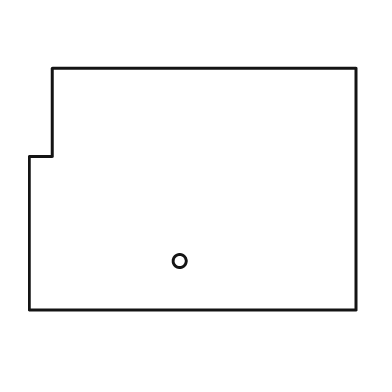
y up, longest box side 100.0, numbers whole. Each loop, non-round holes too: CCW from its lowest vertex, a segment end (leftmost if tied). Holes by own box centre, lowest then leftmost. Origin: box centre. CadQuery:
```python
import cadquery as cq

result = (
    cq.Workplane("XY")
    .moveTo(-50.0, -37.0)
    .lineTo(50.0, -37.0)
    .lineTo(50.0, 37.0)
    .lineTo(-43.0, 37.0)
    .lineTo(-43.0, 10.0)
    .lineTo(-50.0, 10.0)
    .close()
    .moveTo(-4.0, -22.0)
    .circle(2.0)
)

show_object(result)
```